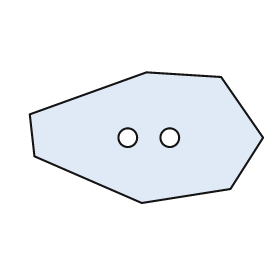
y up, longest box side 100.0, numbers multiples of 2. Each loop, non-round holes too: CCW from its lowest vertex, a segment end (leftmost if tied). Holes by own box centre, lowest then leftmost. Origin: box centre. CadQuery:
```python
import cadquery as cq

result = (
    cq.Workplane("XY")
    .moveTo(-2.0, -28.0)
    .lineTo(36.0, -22.0)
    .lineTo(50.0, 0.0)
    .lineTo(32.0, 26.0)
    .lineTo(0.0, 28.0)
    .lineTo(-50.0, 10.0)
    .lineTo(-48.0, -8.0)
    .close()
    .moveTo(-8.0, 0.0)
    .circle(4.0)
    .moveTo(10.0, 0.0)
    .circle(4.0)
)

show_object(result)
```